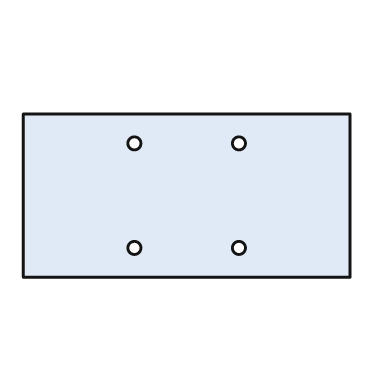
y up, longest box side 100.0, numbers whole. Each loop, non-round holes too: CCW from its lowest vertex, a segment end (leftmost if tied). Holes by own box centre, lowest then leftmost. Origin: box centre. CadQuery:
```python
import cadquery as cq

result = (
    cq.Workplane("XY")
    .moveTo(-50.0, -25.0)
    .lineTo(50.0, -25.0)
    .lineTo(50.0, 25.0)
    .lineTo(-50.0, 25.0)
    .close()
    .moveTo(-16.0, -16.0)
    .circle(2.0)
    .moveTo(16.0, -16.0)
    .circle(2.0)
    .moveTo(-16.0, 16.0)
    .circle(2.0)
    .moveTo(16.0, 16.0)
    .circle(2.0)
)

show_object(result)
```